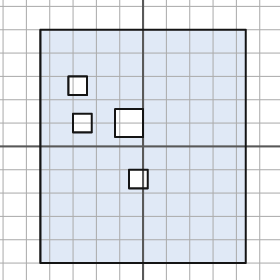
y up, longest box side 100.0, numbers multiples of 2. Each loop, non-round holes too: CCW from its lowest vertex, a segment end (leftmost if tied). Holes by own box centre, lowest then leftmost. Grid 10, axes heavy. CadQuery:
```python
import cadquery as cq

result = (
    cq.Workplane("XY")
    .moveTo(-44.0, -50.0)
    .lineTo(44.0, -50.0)
    .lineTo(44.0, 50.0)
    .lineTo(-44.0, 50.0)
    .close()
    .moveTo(-6.0, -18.0)
    .lineTo(2.0, -18.0)
    .lineTo(2.0, -10.0)
    .lineTo(-6.0, -10.0)
    .close()
    .moveTo(-30.0, 6.0)
    .lineTo(-22.0, 6.0)
    .lineTo(-22.0, 14.0)
    .lineTo(-30.0, 14.0)
    .close()
    .moveTo(-12.0, 4.0)
    .lineTo(0.0, 4.0)
    .lineTo(0.0, 16.0)
    .lineTo(-12.0, 16.0)
    .close()
    .moveTo(-32.0, 22.0)
    .lineTo(-24.0, 22.0)
    .lineTo(-24.0, 30.0)
    .lineTo(-32.0, 30.0)
    .close()
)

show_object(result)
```